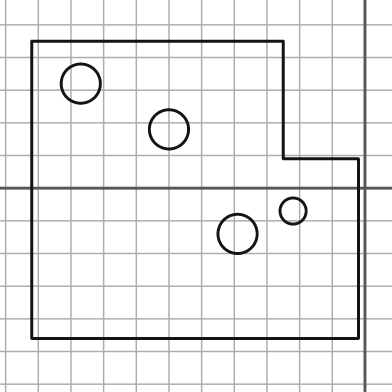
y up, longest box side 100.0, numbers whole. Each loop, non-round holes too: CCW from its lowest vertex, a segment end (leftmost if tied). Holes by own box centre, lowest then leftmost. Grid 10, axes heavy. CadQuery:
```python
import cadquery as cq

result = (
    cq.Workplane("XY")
    .moveTo(-102.0, -46.0)
    .lineTo(-2.0, -46.0)
    .lineTo(-2.0, 9.0)
    .lineTo(-25.0, 9.0)
    .lineTo(-25.0, 45.0)
    .lineTo(-102.0, 45.0)
    .close()
    .moveTo(-39.0, -14.0)
    .circle(6.0)
    .moveTo(-22.0, -7.0)
    .circle(4.0)
    .moveTo(-60.0, 18.0)
    .circle(6.0)
    .moveTo(-87.0, 32.0)
    .circle(6.0)
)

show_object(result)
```